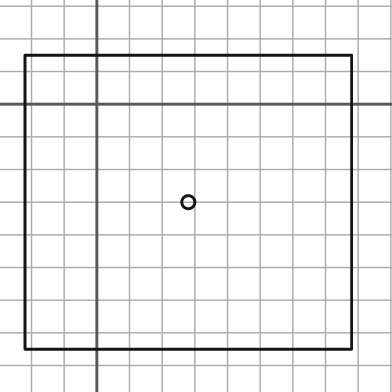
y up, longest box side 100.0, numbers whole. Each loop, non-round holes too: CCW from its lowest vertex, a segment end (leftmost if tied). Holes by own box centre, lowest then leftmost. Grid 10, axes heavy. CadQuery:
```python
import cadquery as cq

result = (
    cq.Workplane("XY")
    .moveTo(-22.0, -75.0)
    .lineTo(78.0, -75.0)
    .lineTo(78.0, 15.0)
    .lineTo(-22.0, 15.0)
    .close()
    .moveTo(28.0, -30.0)
    .circle(2.0)
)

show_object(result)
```